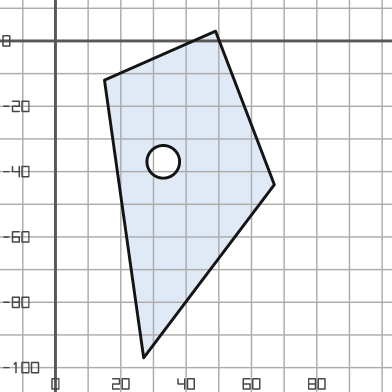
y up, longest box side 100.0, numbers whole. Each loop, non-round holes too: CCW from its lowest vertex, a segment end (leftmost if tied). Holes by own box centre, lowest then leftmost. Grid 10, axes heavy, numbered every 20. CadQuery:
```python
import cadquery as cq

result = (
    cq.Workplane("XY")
    .moveTo(27.0, -97.0)
    .lineTo(67.0, -44.0)
    .lineTo(49.0, 3.0)
    .lineTo(15.0, -12.0)
    .close()
    .moveTo(33.0, -37.0)
    .circle(5.0)
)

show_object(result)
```